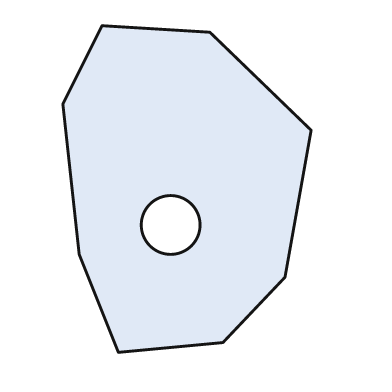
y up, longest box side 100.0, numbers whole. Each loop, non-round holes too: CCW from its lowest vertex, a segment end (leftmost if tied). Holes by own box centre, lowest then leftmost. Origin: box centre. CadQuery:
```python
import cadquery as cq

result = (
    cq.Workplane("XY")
    .moveTo(-21.0, -50.0)
    .lineTo(11.0, -47.0)
    .lineTo(30.0, -27.0)
    .lineTo(38.0, 18.0)
    .lineTo(7.0, 48.0)
    .lineTo(-26.0, 50.0)
    .lineTo(-38.0, 26.0)
    .lineTo(-33.0, -20.0)
    .close()
    .moveTo(-5.0, -11.0)
    .circle(9.0)
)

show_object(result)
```